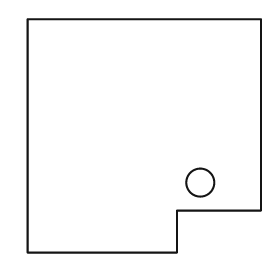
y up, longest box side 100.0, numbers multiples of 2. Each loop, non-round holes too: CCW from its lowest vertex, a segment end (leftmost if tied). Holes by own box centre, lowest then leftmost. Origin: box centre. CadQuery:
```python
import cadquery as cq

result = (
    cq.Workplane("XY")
    .moveTo(-50.0, -50.0)
    .lineTo(14.0, -50.0)
    .lineTo(14.0, -32.0)
    .lineTo(50.0, -32.0)
    .lineTo(50.0, 50.0)
    .lineTo(-50.0, 50.0)
    .close()
    .moveTo(24.0, -20.0)
    .circle(6.0)
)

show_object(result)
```